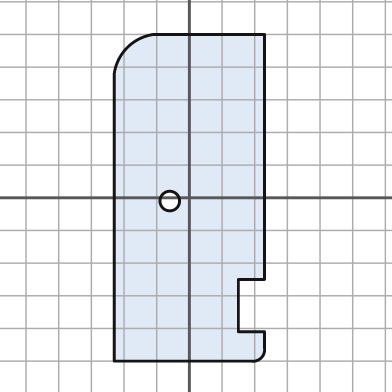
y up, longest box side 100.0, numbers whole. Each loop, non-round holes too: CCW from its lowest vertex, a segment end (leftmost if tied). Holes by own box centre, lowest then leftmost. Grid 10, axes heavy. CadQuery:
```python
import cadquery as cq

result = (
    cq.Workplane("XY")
    .moveTo(-23.0, -50.0)
    .lineTo(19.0, -50.0)
    .threePointArc((22.0, -49.0), (23.0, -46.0))
    .lineTo(23.0, -41.0)
    .lineTo(15.0, -41.0)
    .lineTo(15.0, -25.0)
    .lineTo(23.0, -25.0)
    .lineTo(23.0, 50.0)
    .lineTo(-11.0, 50.0)
    .threePointArc((-19.0, 46.0), (-23.0, 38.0))
    .close()
    .moveTo(-6.0, -1.0)
    .circle(3.0)
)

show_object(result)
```